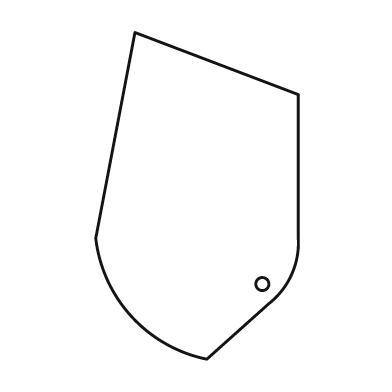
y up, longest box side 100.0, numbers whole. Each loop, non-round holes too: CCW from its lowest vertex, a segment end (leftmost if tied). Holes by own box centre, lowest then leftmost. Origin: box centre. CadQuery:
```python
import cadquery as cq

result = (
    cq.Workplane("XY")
    .moveTo(3.0, -50.0)
    .lineTo(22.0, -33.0)
    .threePointArc((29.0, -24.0), (31.0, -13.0))
    .lineTo(31.0, 31.0)
    .lineTo(-19.0, 50.0)
    .lineTo(-31.0, -13.0)
    .threePointArc((-20.0, -37.0), (3.0, -50.0))
    .close()
    .moveTo(20.0, -27.0)
    .circle(2.0)
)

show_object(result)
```